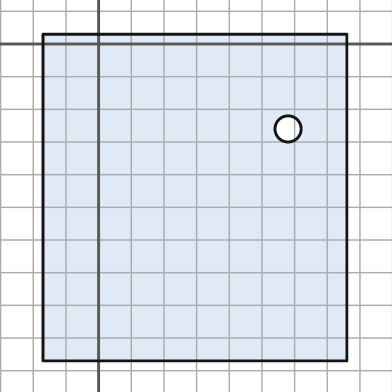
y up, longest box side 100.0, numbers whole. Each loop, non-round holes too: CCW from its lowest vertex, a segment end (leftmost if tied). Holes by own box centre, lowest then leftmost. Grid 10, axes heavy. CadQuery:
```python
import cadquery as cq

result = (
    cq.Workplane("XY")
    .moveTo(-17.0, -97.0)
    .lineTo(76.0, -97.0)
    .lineTo(76.0, 3.0)
    .lineTo(-17.0, 3.0)
    .close()
    .moveTo(58.0, -26.0)
    .circle(4.0)
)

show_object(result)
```